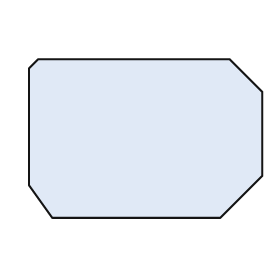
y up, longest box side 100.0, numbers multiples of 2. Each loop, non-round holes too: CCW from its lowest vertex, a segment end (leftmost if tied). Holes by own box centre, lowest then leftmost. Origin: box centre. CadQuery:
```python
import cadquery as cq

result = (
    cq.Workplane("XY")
    .moveTo(-40.0, -34.0)
    .lineTo(32.0, -34.0)
    .lineTo(50.0, -16.0)
    .lineTo(50.0, 20.0)
    .lineTo(36.0, 34.0)
    .lineTo(-46.0, 34.0)
    .lineTo(-50.0, 30.0)
    .lineTo(-50.0, -20.0)
    .close()
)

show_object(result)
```